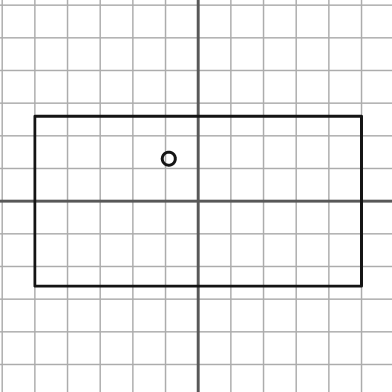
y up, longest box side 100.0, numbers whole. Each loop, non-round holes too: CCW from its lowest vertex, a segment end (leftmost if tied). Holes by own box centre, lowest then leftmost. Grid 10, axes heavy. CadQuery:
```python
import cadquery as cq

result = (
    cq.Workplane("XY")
    .moveTo(-50.0, -26.0)
    .lineTo(50.0, -26.0)
    .lineTo(50.0, 26.0)
    .lineTo(-50.0, 26.0)
    .close()
    .moveTo(-9.0, 13.0)
    .circle(2.0)
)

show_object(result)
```